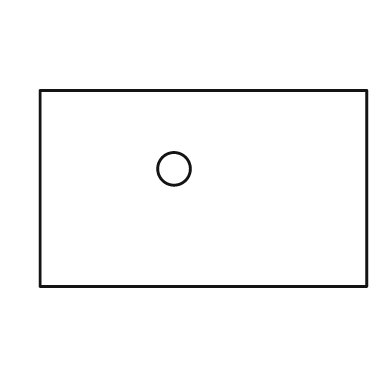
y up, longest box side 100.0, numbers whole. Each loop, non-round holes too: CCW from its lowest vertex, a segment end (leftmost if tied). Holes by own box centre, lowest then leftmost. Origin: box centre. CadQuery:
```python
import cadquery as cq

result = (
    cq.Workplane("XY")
    .moveTo(-50.0, -30.0)
    .lineTo(50.0, -30.0)
    .lineTo(50.0, 30.0)
    .lineTo(-50.0, 30.0)
    .close()
    .moveTo(-9.0, 6.0)
    .circle(5.0)
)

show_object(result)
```